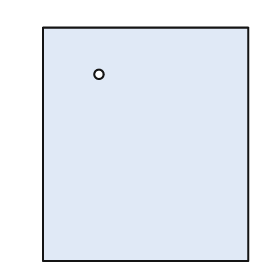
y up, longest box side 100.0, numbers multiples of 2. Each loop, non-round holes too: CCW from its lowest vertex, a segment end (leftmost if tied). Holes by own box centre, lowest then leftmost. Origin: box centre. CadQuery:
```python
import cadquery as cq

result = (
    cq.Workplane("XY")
    .moveTo(-44.0, -50.0)
    .lineTo(44.0, -50.0)
    .lineTo(44.0, 50.0)
    .lineTo(-44.0, 50.0)
    .close()
    .moveTo(-20.0, 30.0)
    .circle(2.0)
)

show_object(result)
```